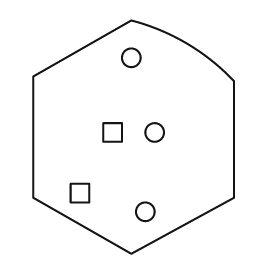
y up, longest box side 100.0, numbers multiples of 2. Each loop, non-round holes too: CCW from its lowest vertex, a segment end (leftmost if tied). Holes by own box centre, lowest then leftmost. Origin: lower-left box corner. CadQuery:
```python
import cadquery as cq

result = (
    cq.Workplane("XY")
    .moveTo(42.0, 0.0)
    .lineTo(86.0, 24.0)
    .lineTo(86.0, 74.0)
    .threePointArc((66.0, 90.0), (42.0, 100.0))
    .lineTo(0.0, 76.0)
    .lineTo(0.0, 24.0)
    .close()
    .moveTo(48.0, 18.0)
    .circle(4.0)
    .moveTo(16.0, 22.0)
    .lineTo(24.0, 22.0)
    .lineTo(24.0, 30.0)
    .lineTo(16.0, 30.0)
    .close()
    .moveTo(30.0, 48.0)
    .lineTo(38.0, 48.0)
    .lineTo(38.0, 56.0)
    .lineTo(30.0, 56.0)
    .close()
    .moveTo(52.0, 52.0)
    .circle(4.0)
    .moveTo(42.0, 84.0)
    .circle(4.0)
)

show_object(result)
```